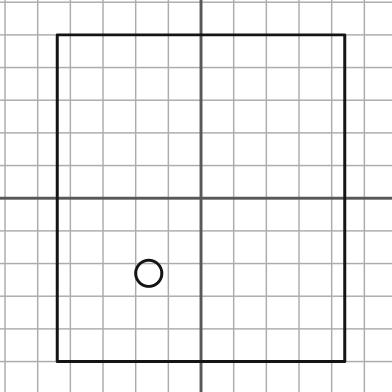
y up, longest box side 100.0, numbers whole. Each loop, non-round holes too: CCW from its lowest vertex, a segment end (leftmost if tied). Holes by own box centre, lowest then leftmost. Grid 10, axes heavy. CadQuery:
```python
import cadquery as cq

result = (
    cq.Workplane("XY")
    .moveTo(-44.0, -50.0)
    .lineTo(44.0, -50.0)
    .lineTo(44.0, 50.0)
    .lineTo(-44.0, 50.0)
    .close()
    .moveTo(-16.0, -23.0)
    .circle(4.0)
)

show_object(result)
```